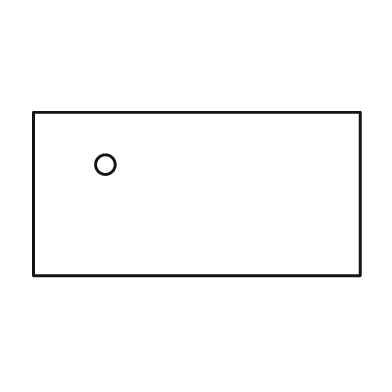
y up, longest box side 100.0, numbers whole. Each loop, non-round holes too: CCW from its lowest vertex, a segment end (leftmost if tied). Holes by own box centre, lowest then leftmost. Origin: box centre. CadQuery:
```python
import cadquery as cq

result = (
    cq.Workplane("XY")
    .moveTo(-50.0, -25.0)
    .lineTo(50.0, -25.0)
    .lineTo(50.0, 25.0)
    .lineTo(-50.0, 25.0)
    .close()
    .moveTo(-28.0, 9.0)
    .circle(3.0)
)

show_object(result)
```